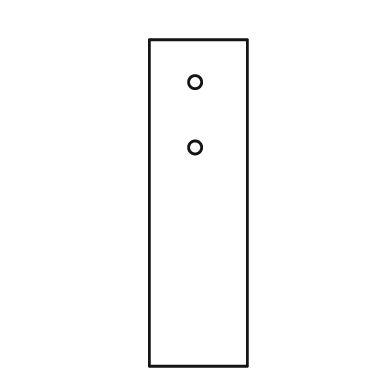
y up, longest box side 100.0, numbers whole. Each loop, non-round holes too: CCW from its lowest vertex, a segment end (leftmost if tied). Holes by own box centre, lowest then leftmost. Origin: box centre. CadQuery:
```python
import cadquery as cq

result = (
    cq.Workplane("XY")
    .moveTo(-15.0, -50.0)
    .lineTo(15.0, -50.0)
    .lineTo(15.0, 50.0)
    .lineTo(-15.0, 50.0)
    .close()
    .moveTo(-1.0, 17.0)
    .circle(2.0)
    .moveTo(-1.0, 37.0)
    .circle(2.0)
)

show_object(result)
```